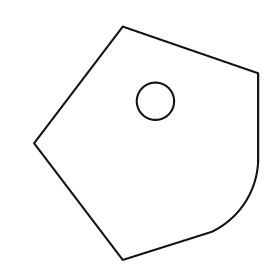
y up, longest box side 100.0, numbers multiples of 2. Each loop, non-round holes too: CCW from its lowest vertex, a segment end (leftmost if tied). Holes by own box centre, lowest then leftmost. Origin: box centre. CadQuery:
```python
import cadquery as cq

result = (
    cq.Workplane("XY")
    .moveTo(-10.0, -50.0)
    .lineTo(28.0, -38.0)
    .threePointArc((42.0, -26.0), (48.0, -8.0))
    .lineTo(48.0, 30.0)
    .lineTo(-10.0, 50.0)
    .lineTo(-48.0, 0.0)
    .close()
    .moveTo(4.0, 18.0)
    .circle(8.0)
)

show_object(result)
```